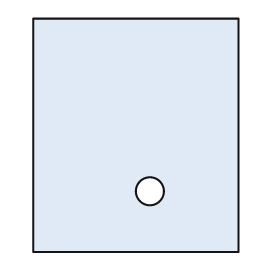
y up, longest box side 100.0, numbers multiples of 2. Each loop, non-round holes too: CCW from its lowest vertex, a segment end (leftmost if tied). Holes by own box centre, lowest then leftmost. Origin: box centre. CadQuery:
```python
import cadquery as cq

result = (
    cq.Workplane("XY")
    .moveTo(-44.0, -50.0)
    .lineTo(44.0, -50.0)
    .lineTo(44.0, 50.0)
    .lineTo(-44.0, 50.0)
    .close()
    .moveTo(6.0, -24.0)
    .circle(6.0)
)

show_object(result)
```